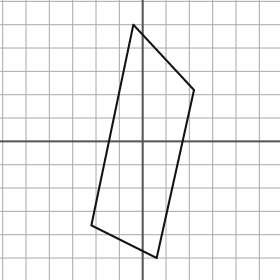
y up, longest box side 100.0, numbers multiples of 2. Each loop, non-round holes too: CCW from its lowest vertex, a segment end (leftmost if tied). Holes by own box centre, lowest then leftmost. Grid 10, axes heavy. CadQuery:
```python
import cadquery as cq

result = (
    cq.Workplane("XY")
    .moveTo(6.0, -50.0)
    .lineTo(22.0, 22.0)
    .lineTo(-4.0, 50.0)
    .lineTo(-22.0, -36.0)
    .close()
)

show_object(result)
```